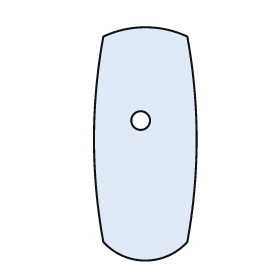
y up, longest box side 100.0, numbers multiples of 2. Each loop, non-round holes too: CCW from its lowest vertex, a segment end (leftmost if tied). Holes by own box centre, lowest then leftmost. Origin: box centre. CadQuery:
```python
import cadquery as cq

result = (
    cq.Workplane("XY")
    .moveTo(-18.0, -42.0)
    .threePointArc((0.0, -50.0), (18.0, -42.0))
    .threePointArc((22.0, 2.0), (18.0, 46.0))
    .threePointArc((0.0, 50.0), (-18.0, 46.0))
    .threePointArc((-22.0, 2.0), (-18.0, -42.0))
    .close()
    .moveTo(-2.0, 10.0)
    .circle(4.0)
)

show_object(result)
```